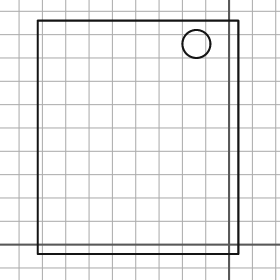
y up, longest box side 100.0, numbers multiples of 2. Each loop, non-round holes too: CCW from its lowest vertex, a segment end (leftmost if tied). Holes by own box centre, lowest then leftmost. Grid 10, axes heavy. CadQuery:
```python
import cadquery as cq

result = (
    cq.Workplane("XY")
    .moveTo(-82.0, -4.0)
    .lineTo(4.0, -4.0)
    .lineTo(4.0, 96.0)
    .lineTo(-82.0, 96.0)
    .close()
    .moveTo(-14.0, 86.0)
    .circle(6.0)
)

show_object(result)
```